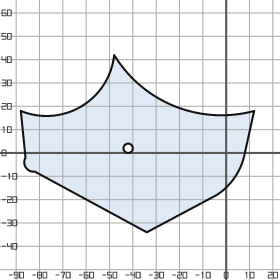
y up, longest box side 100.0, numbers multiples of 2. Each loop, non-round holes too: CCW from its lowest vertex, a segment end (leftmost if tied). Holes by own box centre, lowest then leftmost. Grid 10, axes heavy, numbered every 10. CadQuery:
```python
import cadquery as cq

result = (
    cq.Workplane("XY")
    .moveTo(-34.0, -34.0)
    .lineTo(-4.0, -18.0)
    .threePointArc((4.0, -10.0), (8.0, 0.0))
    .lineTo(12.0, 18.0)
    .threePointArc((-22.0, 20.0), (-48.0, 42.0))
    .threePointArc((-62.0, 20.0), (-88.0, 18.0))
    .lineTo(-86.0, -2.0)
    .threePointArc((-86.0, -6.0), (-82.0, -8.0))
    .close()
    .moveTo(-42.0, 2.0)
    .circle(2.0)
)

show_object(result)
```